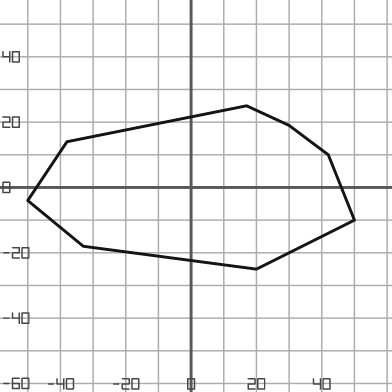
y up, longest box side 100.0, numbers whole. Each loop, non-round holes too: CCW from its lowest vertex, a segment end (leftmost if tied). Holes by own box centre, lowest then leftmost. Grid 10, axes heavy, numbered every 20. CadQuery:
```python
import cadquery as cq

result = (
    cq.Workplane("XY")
    .moveTo(20.0, -25.0)
    .lineTo(50.0, -10.0)
    .lineTo(42.0, 10.0)
    .lineTo(30.0, 19.0)
    .lineTo(17.0, 25.0)
    .lineTo(-38.0, 14.0)
    .lineTo(-50.0, -4.0)
    .lineTo(-33.0, -18.0)
    .close()
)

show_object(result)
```